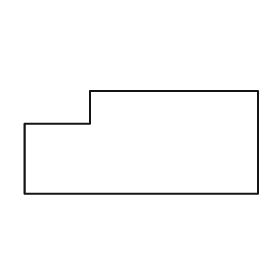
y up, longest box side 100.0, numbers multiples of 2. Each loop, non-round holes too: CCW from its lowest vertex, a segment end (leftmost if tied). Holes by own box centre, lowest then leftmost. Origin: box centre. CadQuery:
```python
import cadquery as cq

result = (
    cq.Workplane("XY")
    .moveTo(-50.0, -22.0)
    .lineTo(50.0, -22.0)
    .lineTo(50.0, 22.0)
    .lineTo(-22.0, 22.0)
    .lineTo(-22.0, 8.0)
    .lineTo(-50.0, 8.0)
    .close()
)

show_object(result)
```